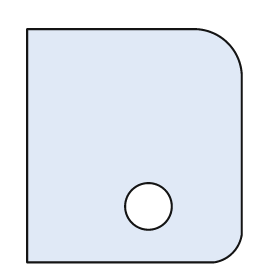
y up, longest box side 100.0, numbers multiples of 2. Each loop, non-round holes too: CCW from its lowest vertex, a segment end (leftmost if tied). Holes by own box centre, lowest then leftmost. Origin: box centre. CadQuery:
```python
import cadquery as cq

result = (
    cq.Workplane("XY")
    .moveTo(-46.0, -50.0)
    .lineTo(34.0, -50.0)
    .threePointArc((42.0, -46.0), (46.0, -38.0))
    .lineTo(46.0, 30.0)
    .threePointArc((40.0, 44.0), (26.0, 50.0))
    .lineTo(-46.0, 50.0)
    .close()
    .moveTo(6.0, -26.0)
    .circle(10.0)
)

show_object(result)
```